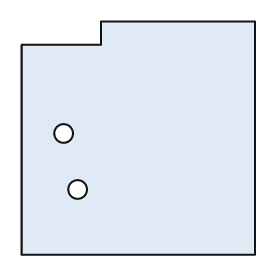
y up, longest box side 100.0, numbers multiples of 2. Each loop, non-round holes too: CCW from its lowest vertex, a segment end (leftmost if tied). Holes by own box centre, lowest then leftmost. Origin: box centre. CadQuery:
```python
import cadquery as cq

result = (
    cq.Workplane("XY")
    .moveTo(-50.0, -50.0)
    .lineTo(50.0, -50.0)
    .lineTo(50.0, 50.0)
    .lineTo(-16.0, 50.0)
    .lineTo(-16.0, 40.0)
    .lineTo(-50.0, 40.0)
    .close()
    .moveTo(-26.0, -22.0)
    .circle(4.0)
    .moveTo(-32.0, 2.0)
    .circle(4.0)
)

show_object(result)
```